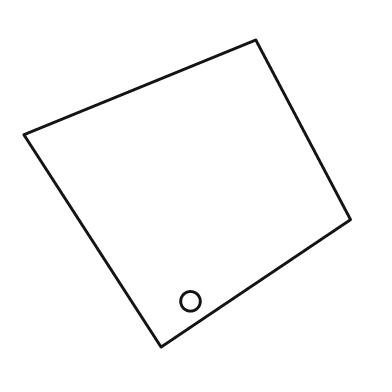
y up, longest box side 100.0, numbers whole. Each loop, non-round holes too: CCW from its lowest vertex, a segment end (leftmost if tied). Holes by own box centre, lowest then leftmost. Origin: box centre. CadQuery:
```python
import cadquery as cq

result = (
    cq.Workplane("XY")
    .moveTo(-8.0, -47.0)
    .lineTo(50.0, -8.0)
    .lineTo(21.0, 47.0)
    .lineTo(-50.0, 18.0)
    .close()
    .moveTo(1.0, -33.0)
    .circle(3.0)
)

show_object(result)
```